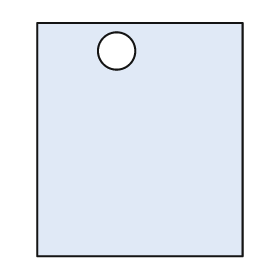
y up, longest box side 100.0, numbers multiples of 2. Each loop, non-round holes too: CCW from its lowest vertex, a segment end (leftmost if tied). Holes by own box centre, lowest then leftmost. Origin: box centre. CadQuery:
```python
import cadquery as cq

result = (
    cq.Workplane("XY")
    .moveTo(-44.0, -50.0)
    .lineTo(44.0, -50.0)
    .lineTo(44.0, 50.0)
    .lineTo(-44.0, 50.0)
    .close()
    .moveTo(-10.0, 38.0)
    .circle(8.0)
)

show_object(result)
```